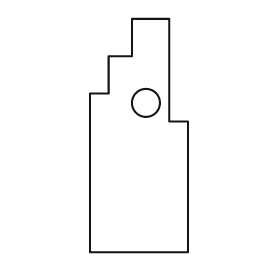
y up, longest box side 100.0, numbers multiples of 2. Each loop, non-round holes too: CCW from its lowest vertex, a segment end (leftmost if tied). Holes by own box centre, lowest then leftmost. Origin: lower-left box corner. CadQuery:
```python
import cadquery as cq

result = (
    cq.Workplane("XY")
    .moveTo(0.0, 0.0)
    .lineTo(42.0, 0.0)
    .lineTo(42.0, 56.0)
    .lineTo(34.0, 56.0)
    .lineTo(34.0, 100.0)
    .lineTo(18.0, 100.0)
    .lineTo(18.0, 84.0)
    .lineTo(8.0, 84.0)
    .lineTo(8.0, 68.0)
    .lineTo(0.0, 68.0)
    .close()
    .moveTo(24.0, 64.0)
    .circle(6.0)
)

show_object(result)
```